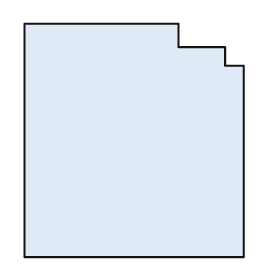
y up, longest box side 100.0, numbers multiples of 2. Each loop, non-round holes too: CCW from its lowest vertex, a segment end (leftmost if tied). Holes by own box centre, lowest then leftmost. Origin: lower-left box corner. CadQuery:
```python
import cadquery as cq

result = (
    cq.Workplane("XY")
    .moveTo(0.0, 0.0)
    .lineTo(94.0, 0.0)
    .lineTo(94.0, 82.0)
    .lineTo(86.0, 82.0)
    .lineTo(86.0, 90.0)
    .lineTo(66.0, 90.0)
    .lineTo(66.0, 100.0)
    .lineTo(0.0, 100.0)
    .close()
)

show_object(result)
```